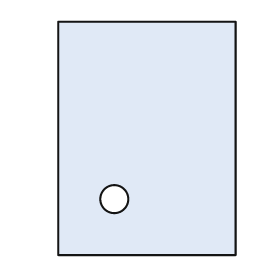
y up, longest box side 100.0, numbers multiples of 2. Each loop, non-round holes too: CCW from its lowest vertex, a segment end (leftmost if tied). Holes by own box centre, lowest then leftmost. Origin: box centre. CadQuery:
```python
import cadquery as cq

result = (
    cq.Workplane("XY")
    .moveTo(-38.0, -50.0)
    .lineTo(38.0, -50.0)
    .lineTo(38.0, 50.0)
    .lineTo(-38.0, 50.0)
    .close()
    .moveTo(-14.0, -26.0)
    .circle(6.0)
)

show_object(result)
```